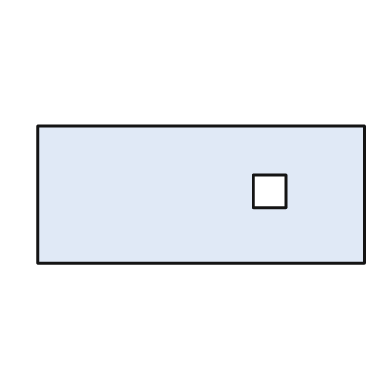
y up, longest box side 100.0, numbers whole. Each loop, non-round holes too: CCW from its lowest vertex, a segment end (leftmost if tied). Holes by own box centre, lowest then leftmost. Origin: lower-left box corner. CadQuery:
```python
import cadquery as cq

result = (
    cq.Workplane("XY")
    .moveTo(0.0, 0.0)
    .lineTo(100.0, 0.0)
    .lineTo(100.0, 42.0)
    .lineTo(0.0, 42.0)
    .close()
    .moveTo(66.0, 17.0)
    .lineTo(76.0, 17.0)
    .lineTo(76.0, 27.0)
    .lineTo(66.0, 27.0)
    .close()
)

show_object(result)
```